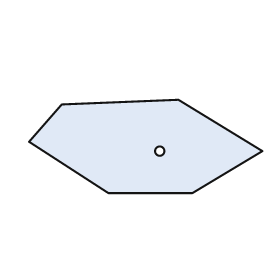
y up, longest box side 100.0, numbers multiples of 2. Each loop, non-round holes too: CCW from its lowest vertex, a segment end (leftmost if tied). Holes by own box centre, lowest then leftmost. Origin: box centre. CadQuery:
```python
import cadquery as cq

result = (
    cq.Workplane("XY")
    .moveTo(-16.0, -20.0)
    .lineTo(20.0, -20.0)
    .lineTo(50.0, -2.0)
    .lineTo(14.0, 20.0)
    .lineTo(-36.0, 18.0)
    .lineTo(-50.0, 2.0)
    .close()
    .moveTo(6.0, -2.0)
    .circle(2.0)
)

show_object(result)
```